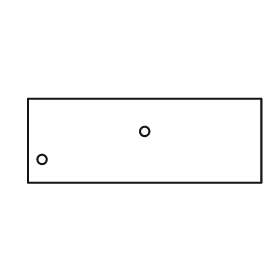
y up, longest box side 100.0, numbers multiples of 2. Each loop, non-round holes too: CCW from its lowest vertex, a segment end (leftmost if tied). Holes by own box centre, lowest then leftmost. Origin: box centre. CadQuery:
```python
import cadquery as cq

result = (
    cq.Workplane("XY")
    .moveTo(-50.0, -18.0)
    .lineTo(50.0, -18.0)
    .lineTo(50.0, 18.0)
    .lineTo(-50.0, 18.0)
    .close()
    .moveTo(-44.0, -8.0)
    .circle(2.0)
    .moveTo(0.0, 4.0)
    .circle(2.0)
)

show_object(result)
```